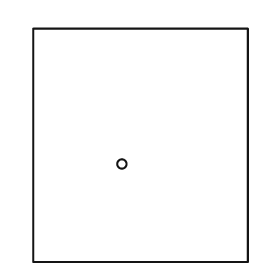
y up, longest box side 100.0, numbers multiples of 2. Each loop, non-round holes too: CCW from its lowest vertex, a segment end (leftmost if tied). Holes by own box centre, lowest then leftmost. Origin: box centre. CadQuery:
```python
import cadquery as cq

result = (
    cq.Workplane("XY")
    .moveTo(-46.0, -50.0)
    .lineTo(46.0, -50.0)
    .lineTo(46.0, 50.0)
    .lineTo(-46.0, 50.0)
    .close()
    .moveTo(-8.0, -8.0)
    .circle(2.0)
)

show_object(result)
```